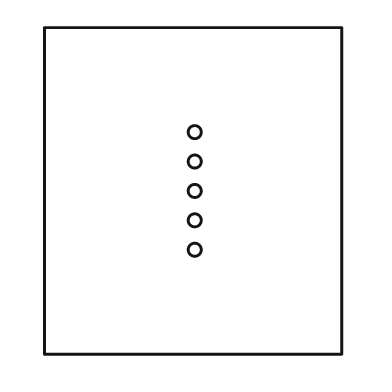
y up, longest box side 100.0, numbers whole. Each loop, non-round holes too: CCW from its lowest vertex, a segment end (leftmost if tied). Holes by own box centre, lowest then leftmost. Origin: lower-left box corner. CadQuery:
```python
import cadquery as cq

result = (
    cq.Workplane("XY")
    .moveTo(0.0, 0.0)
    .lineTo(91.0, 0.0)
    .lineTo(91.0, 100.0)
    .lineTo(0.0, 100.0)
    .close()
    .moveTo(46.0, 32.0)
    .circle(2.0)
    .moveTo(46.0, 41.0)
    .circle(2.0)
    .moveTo(46.0, 50.0)
    .circle(2.0)
    .moveTo(46.0, 59.0)
    .circle(2.0)
    .moveTo(46.0, 68.0)
    .circle(2.0)
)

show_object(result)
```